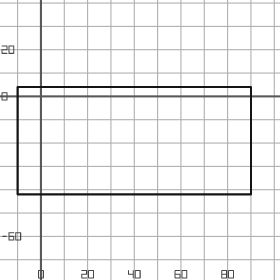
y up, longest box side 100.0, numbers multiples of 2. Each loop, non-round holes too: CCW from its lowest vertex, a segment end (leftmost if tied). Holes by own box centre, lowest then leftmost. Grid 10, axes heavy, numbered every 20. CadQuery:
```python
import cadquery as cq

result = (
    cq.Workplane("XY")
    .moveTo(-10.0, -42.0)
    .lineTo(90.0, -42.0)
    .lineTo(90.0, 4.0)
    .lineTo(-10.0, 4.0)
    .close()
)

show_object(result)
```